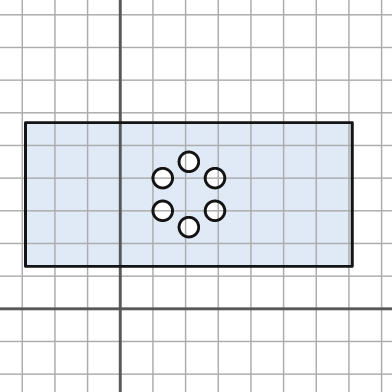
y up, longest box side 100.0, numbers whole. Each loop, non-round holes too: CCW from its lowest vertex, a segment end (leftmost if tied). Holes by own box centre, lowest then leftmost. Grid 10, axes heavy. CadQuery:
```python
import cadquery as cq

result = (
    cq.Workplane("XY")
    .moveTo(-29.0, 13.0)
    .lineTo(71.0, 13.0)
    .lineTo(71.0, 57.0)
    .lineTo(-29.0, 57.0)
    .close()
    .moveTo(21.0, 25.0)
    .circle(3.0)
    .moveTo(13.0, 30.0)
    .circle(3.0)
    .moveTo(29.0, 30.0)
    .circle(3.0)
    .moveTo(13.0, 40.0)
    .circle(3.0)
    .moveTo(29.0, 40.0)
    .circle(3.0)
    .moveTo(21.0, 45.0)
    .circle(3.0)
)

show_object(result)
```